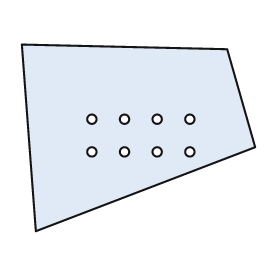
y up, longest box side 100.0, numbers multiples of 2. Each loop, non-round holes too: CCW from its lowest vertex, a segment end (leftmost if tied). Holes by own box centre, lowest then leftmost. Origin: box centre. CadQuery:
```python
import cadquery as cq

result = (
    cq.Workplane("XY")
    .moveTo(-44.0, -40.0)
    .lineTo(50.0, -4.0)
    .lineTo(38.0, 38.0)
    .lineTo(-50.0, 40.0)
    .close()
    .moveTo(-20.0, -6.0)
    .circle(2.0)
    .moveTo(-6.0, -6.0)
    .circle(2.0)
    .moveTo(8.0, -6.0)
    .circle(2.0)
    .moveTo(22.0, -6.0)
    .circle(2.0)
    .moveTo(-20.0, 8.0)
    .circle(2.0)
    .moveTo(-6.0, 8.0)
    .circle(2.0)
    .moveTo(8.0, 8.0)
    .circle(2.0)
    .moveTo(22.0, 8.0)
    .circle(2.0)
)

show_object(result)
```